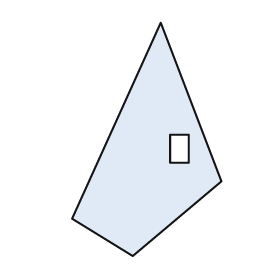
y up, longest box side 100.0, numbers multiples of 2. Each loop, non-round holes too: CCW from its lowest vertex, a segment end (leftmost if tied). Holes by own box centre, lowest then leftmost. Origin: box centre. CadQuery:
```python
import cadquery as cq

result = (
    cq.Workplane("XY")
    .moveTo(-6.0, -50.0)
    .lineTo(32.0, -18.0)
    .lineTo(6.0, 50.0)
    .lineTo(-32.0, -34.0)
    .close()
    .moveTo(10.0, -10.0)
    .lineTo(18.0, -10.0)
    .lineTo(18.0, 2.0)
    .lineTo(10.0, 2.0)
    .close()
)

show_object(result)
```